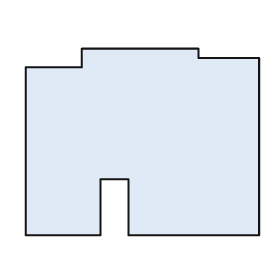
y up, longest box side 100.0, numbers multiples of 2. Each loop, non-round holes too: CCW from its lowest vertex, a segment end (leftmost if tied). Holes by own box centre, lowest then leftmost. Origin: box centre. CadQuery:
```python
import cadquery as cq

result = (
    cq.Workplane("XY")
    .moveTo(-50.0, -40.0)
    .lineTo(-18.0, -40.0)
    .lineTo(-18.0, -16.0)
    .lineTo(-6.0, -16.0)
    .lineTo(-6.0, -40.0)
    .lineTo(50.0, -40.0)
    .lineTo(50.0, 36.0)
    .lineTo(24.0, 36.0)
    .lineTo(24.0, 40.0)
    .lineTo(-26.0, 40.0)
    .lineTo(-26.0, 32.0)
    .lineTo(-50.0, 32.0)
    .close()
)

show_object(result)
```